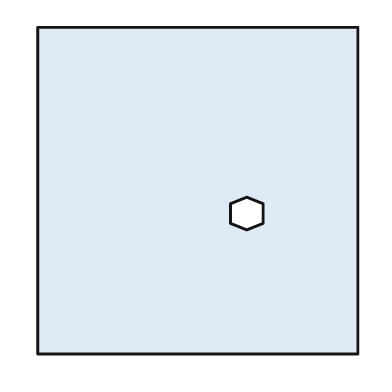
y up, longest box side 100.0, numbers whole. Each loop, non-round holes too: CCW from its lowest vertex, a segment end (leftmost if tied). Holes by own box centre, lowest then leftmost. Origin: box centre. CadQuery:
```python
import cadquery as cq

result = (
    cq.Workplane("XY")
    .moveTo(-49.0, -50.0)
    .lineTo(49.0, -50.0)
    .lineTo(49.0, 50.0)
    .lineTo(-49.0, 50.0)
    .close()
    .moveTo(15.0, -12.0)
    .lineTo(20.0, -10.0)
    .lineTo(20.0, -4.0)
    .lineTo(15.0, -2.0)
    .lineTo(10.0, -4.0)
    .lineTo(10.0, -10.0)
    .close()
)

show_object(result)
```